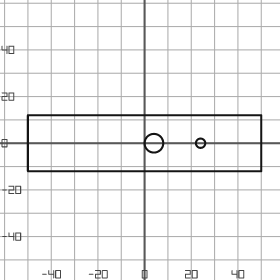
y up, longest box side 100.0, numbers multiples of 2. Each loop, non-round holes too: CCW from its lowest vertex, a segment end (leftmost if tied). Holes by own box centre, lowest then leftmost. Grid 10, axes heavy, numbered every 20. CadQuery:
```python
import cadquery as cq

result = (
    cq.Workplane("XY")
    .moveTo(-50.0, -12.0)
    .lineTo(50.0, -12.0)
    .lineTo(50.0, 12.0)
    .lineTo(-50.0, 12.0)
    .close()
    .moveTo(4.0, 0.0)
    .circle(4.0)
    .moveTo(24.0, 0.0)
    .circle(2.0)
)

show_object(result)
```